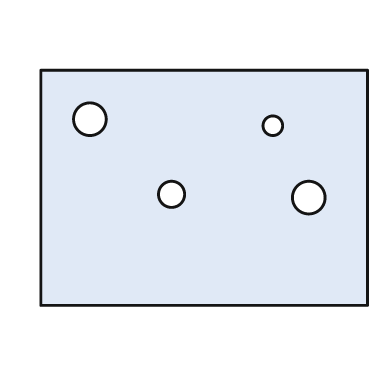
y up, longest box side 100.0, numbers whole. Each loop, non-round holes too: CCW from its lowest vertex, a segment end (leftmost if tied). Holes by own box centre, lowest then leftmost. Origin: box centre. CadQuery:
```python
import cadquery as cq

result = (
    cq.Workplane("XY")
    .moveTo(-50.0, -36.0)
    .lineTo(50.0, -36.0)
    .lineTo(50.0, 36.0)
    .lineTo(-50.0, 36.0)
    .close()
    .moveTo(32.0, -3.0)
    .circle(5.0)
    .moveTo(-10.0, -2.0)
    .circle(4.0)
    .moveTo(21.0, 19.0)
    .circle(3.0)
    .moveTo(-35.0, 21.0)
    .circle(5.0)
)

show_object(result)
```